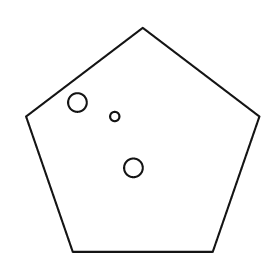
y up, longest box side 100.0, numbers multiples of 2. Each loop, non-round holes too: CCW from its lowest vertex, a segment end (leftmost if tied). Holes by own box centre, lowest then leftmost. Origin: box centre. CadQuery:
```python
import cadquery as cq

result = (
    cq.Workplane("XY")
    .moveTo(-30.0, -48.0)
    .lineTo(30.0, -48.0)
    .lineTo(50.0, 10.0)
    .lineTo(0.0, 48.0)
    .lineTo(-50.0, 10.0)
    .close()
    .moveTo(-4.0, -12.0)
    .circle(4.0)
    .moveTo(-12.0, 10.0)
    .circle(2.0)
    .moveTo(-28.0, 16.0)
    .circle(4.0)
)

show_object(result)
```